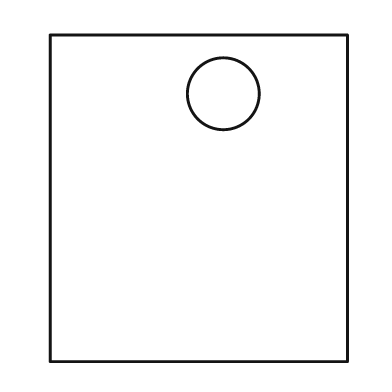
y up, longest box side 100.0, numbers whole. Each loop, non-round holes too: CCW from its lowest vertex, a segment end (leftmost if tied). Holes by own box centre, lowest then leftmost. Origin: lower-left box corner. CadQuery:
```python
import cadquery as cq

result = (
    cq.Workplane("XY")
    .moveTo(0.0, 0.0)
    .lineTo(91.0, 0.0)
    .lineTo(91.0, 100.0)
    .lineTo(0.0, 100.0)
    .close()
    .moveTo(53.0, 82.0)
    .circle(11.0)
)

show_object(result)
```